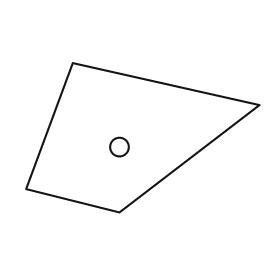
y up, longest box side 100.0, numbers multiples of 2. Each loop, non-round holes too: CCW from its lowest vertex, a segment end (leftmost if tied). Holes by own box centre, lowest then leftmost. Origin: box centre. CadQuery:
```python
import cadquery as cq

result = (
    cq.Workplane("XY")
    .moveTo(-10.0, -32.0)
    .lineTo(50.0, 14.0)
    .lineTo(-30.0, 32.0)
    .lineTo(-50.0, -22.0)
    .close()
    .moveTo(-10.0, -4.0)
    .circle(4.0)
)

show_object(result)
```